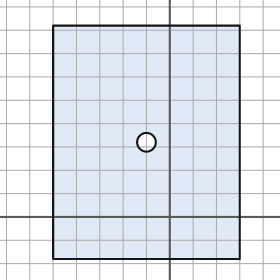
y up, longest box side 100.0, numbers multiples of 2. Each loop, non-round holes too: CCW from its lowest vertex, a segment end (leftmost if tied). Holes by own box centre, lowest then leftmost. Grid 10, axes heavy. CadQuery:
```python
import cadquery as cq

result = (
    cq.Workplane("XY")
    .moveTo(-50.0, -18.0)
    .lineTo(30.0, -18.0)
    .lineTo(30.0, 82.0)
    .lineTo(-50.0, 82.0)
    .close()
    .moveTo(-10.0, 32.0)
    .circle(4.0)
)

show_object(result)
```